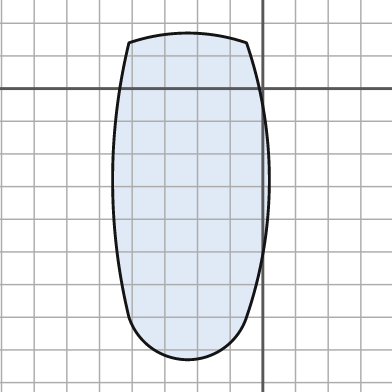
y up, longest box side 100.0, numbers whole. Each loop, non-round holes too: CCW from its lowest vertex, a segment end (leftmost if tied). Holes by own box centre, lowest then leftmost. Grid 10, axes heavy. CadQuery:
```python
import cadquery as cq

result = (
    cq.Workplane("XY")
    .moveTo(-41.0, -70.0)
    .threePointArc((-23.0, -83.0), (-5.0, -70.0))
    .threePointArc((2.0, -28.0), (-5.0, 14.0))
    .threePointArc((-23.0, 17.0), (-41.0, 14.0))
    .threePointArc((-46.0, -28.0), (-41.0, -70.0))
    .close()
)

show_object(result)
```